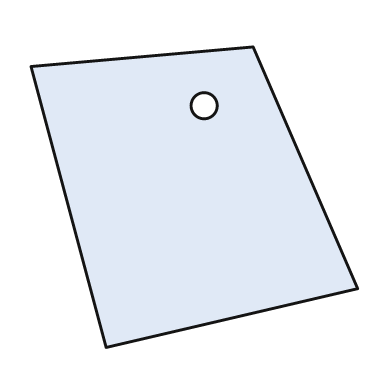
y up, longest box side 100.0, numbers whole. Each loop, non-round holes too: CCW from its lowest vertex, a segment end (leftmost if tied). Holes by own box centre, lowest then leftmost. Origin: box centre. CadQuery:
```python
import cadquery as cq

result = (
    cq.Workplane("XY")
    .moveTo(-27.0, -46.0)
    .lineTo(50.0, -28.0)
    .lineTo(18.0, 46.0)
    .lineTo(-50.0, 40.0)
    .close()
    .moveTo(3.0, 28.0)
    .circle(4.0)
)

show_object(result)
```